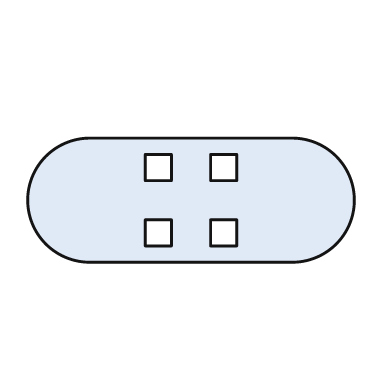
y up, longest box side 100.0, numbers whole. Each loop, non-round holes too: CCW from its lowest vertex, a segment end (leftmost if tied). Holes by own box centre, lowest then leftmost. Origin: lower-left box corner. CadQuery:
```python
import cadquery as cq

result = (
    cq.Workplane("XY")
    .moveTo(19.0, 0.0)
    .lineTo(81.0, 0.0)
    .threePointArc((100.0, 19.0), (81.0, 38.0))
    .lineTo(19.0, 38.0)
    .threePointArc((0.0, 19.0), (19.0, 0.0))
    .close()
    .moveTo(36.0, 5.0)
    .lineTo(44.0, 5.0)
    .lineTo(44.0, 13.0)
    .lineTo(36.0, 13.0)
    .close()
    .moveTo(56.0, 5.0)
    .lineTo(64.0, 5.0)
    .lineTo(64.0, 13.0)
    .lineTo(56.0, 13.0)
    .close()
    .moveTo(36.0, 25.0)
    .lineTo(44.0, 25.0)
    .lineTo(44.0, 33.0)
    .lineTo(36.0, 33.0)
    .close()
    .moveTo(56.0, 25.0)
    .lineTo(64.0, 25.0)
    .lineTo(64.0, 33.0)
    .lineTo(56.0, 33.0)
    .close()
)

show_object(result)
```